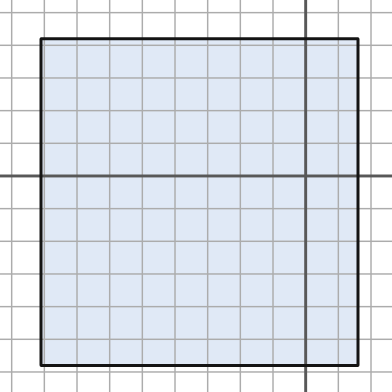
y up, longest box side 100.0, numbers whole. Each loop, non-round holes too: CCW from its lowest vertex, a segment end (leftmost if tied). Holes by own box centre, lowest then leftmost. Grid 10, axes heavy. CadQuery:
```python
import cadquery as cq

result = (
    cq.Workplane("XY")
    .moveTo(-81.0, -58.0)
    .lineTo(16.0, -58.0)
    .lineTo(16.0, 42.0)
    .lineTo(-81.0, 42.0)
    .close()
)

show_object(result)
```